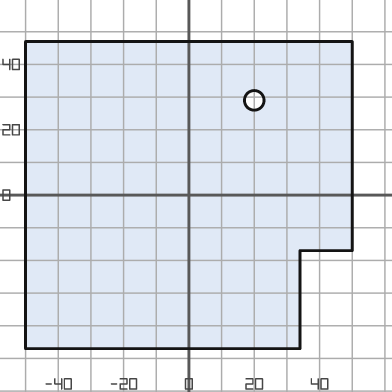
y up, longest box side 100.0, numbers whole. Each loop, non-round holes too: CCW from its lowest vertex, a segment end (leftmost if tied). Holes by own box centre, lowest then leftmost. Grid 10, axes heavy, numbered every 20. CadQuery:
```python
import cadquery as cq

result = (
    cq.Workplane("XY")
    .moveTo(-50.0, -47.0)
    .lineTo(34.0, -47.0)
    .lineTo(34.0, -17.0)
    .lineTo(50.0, -17.0)
    .lineTo(50.0, 47.0)
    .lineTo(-50.0, 47.0)
    .close()
    .moveTo(20.0, 29.0)
    .circle(3.0)
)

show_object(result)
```